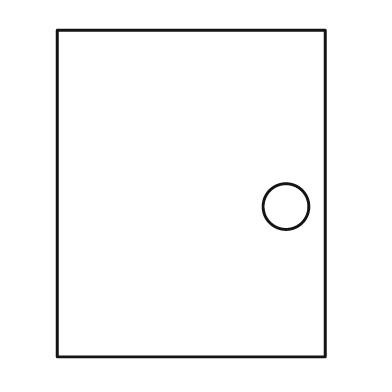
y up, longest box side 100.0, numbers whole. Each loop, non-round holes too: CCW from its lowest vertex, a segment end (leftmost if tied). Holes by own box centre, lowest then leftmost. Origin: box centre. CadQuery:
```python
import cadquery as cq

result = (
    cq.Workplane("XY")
    .moveTo(-41.0, -50.0)
    .lineTo(41.0, -50.0)
    .lineTo(41.0, 50.0)
    .lineTo(-41.0, 50.0)
    .close()
    .moveTo(29.0, -4.0)
    .circle(7.0)
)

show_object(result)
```